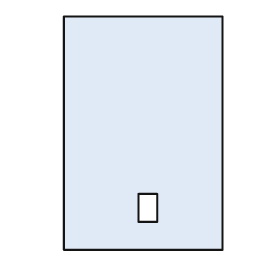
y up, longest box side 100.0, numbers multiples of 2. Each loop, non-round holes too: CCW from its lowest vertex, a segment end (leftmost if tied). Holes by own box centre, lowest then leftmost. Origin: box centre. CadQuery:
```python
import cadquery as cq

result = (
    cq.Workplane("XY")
    .moveTo(-34.0, -50.0)
    .lineTo(34.0, -50.0)
    .lineTo(34.0, 50.0)
    .lineTo(-34.0, 50.0)
    .close()
    .moveTo(-2.0, -38.0)
    .lineTo(6.0, -38.0)
    .lineTo(6.0, -26.0)
    .lineTo(-2.0, -26.0)
    .close()
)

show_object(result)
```